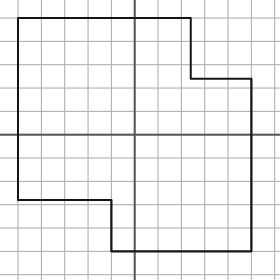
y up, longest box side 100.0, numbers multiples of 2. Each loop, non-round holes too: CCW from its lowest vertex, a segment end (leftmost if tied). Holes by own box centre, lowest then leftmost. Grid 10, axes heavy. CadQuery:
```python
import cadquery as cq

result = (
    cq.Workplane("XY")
    .moveTo(-10.0, -50.0)
    .lineTo(50.0, -50.0)
    .lineTo(50.0, 24.0)
    .lineTo(24.0, 24.0)
    .lineTo(24.0, 50.0)
    .lineTo(-50.0, 50.0)
    .lineTo(-50.0, -28.0)
    .lineTo(-10.0, -28.0)
    .close()
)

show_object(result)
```